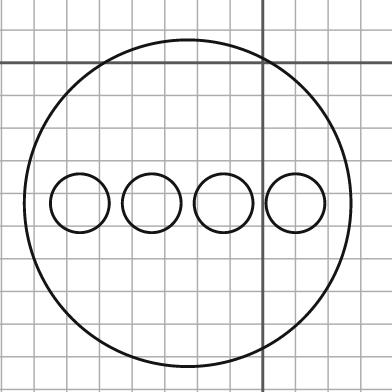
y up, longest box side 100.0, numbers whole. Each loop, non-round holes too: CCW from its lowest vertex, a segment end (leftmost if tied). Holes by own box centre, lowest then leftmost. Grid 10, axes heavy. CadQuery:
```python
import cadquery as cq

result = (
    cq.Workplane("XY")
    .moveTo(-23.0, -43.0)
    .circle(50.0)
    .moveTo(-56.0, -43.0)
    .circle(9.0)
    .moveTo(-34.0, -43.0)
    .circle(9.0)
    .moveTo(-12.0, -43.0)
    .circle(9.0)
    .moveTo(10.0, -43.0)
    .circle(9.0)
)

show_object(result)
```